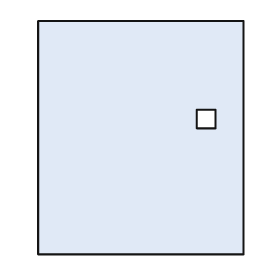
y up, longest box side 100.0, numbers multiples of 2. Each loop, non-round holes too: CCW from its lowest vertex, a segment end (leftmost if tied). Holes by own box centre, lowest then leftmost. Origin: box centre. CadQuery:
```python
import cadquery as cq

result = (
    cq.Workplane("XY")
    .moveTo(-44.0, -50.0)
    .lineTo(44.0, -50.0)
    .lineTo(44.0, 50.0)
    .lineTo(-44.0, 50.0)
    .close()
    .moveTo(24.0, 4.0)
    .lineTo(32.0, 4.0)
    .lineTo(32.0, 12.0)
    .lineTo(24.0, 12.0)
    .close()
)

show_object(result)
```